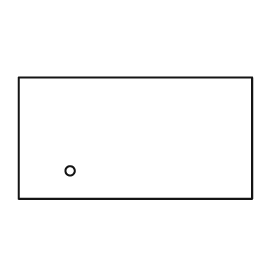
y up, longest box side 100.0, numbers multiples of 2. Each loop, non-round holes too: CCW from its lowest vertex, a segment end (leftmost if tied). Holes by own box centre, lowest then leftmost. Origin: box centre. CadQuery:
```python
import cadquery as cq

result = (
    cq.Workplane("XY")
    .moveTo(-50.0, -26.0)
    .lineTo(50.0, -26.0)
    .lineTo(50.0, 26.0)
    .lineTo(-50.0, 26.0)
    .close()
    .moveTo(-28.0, -14.0)
    .circle(2.0)
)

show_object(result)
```